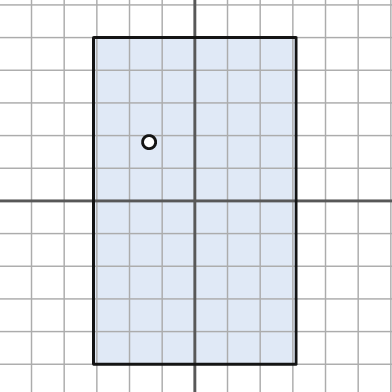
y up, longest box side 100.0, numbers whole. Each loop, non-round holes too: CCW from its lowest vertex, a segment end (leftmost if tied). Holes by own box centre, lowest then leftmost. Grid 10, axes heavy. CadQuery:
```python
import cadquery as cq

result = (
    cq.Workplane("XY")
    .moveTo(-31.0, -50.0)
    .lineTo(31.0, -50.0)
    .lineTo(31.0, 50.0)
    .lineTo(-31.0, 50.0)
    .close()
    .moveTo(-14.0, 18.0)
    .circle(2.0)
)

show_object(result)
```